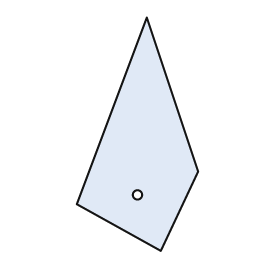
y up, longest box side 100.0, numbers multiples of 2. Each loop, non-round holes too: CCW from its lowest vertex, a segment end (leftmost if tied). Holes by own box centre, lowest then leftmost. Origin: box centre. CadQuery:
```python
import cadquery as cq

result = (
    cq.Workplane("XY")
    .moveTo(10.0, -50.0)
    .lineTo(26.0, -16.0)
    .lineTo(4.0, 50.0)
    .lineTo(-26.0, -30.0)
    .close()
    .moveTo(0.0, -26.0)
    .circle(2.0)
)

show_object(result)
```